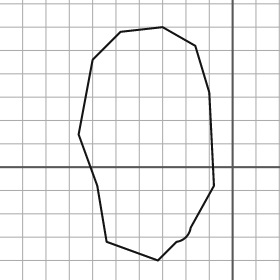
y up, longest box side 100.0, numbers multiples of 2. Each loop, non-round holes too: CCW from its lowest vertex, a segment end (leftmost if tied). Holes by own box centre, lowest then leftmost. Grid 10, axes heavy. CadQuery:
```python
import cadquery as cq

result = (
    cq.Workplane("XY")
    .moveTo(-32.0, -40.0)
    .lineTo(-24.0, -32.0)
    .threePointArc((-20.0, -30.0), (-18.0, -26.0))
    .lineTo(-8.0, -8.0)
    .lineTo(-10.0, 32.0)
    .lineTo(-16.0, 52.0)
    .lineTo(-30.0, 60.0)
    .lineTo(-48.0, 58.0)
    .lineTo(-60.0, 46.0)
    .lineTo(-66.0, 14.0)
    .lineTo(-58.0, -8.0)
    .lineTo(-54.0, -32.0)
    .close()
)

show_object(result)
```